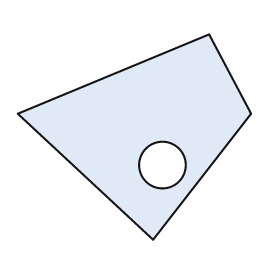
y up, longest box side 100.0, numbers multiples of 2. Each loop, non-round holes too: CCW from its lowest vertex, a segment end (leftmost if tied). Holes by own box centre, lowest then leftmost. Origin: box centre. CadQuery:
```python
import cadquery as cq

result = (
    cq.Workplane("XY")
    .moveTo(8.0, -44.0)
    .lineTo(50.0, 10.0)
    .lineTo(32.0, 44.0)
    .lineTo(-50.0, 10.0)
    .close()
    .moveTo(12.0, -12.0)
    .circle(10.0)
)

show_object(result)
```